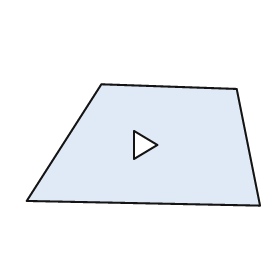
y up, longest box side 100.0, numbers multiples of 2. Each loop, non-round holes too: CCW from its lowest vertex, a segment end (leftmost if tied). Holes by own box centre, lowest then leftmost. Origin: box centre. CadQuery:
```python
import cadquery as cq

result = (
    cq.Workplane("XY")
    .moveTo(50.0, -26.0)
    .lineTo(40.0, 24.0)
    .lineTo(-18.0, 26.0)
    .lineTo(-50.0, -24.0)
    .close()
    .moveTo(-4.0, -6.0)
    .lineTo(6.0, 0.0)
    .lineTo(-4.0, 6.0)
    .close()
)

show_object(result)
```